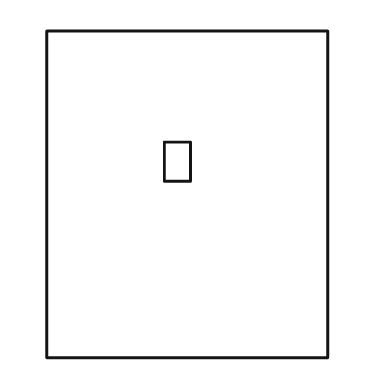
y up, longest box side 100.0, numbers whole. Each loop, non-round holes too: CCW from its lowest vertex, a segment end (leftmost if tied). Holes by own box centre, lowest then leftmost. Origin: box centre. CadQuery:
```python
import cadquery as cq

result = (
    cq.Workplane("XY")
    .moveTo(-43.0, -50.0)
    .lineTo(43.0, -50.0)
    .lineTo(43.0, 50.0)
    .lineTo(-43.0, 50.0)
    .close()
    .moveTo(-7.0, 4.0)
    .lineTo(1.0, 4.0)
    .lineTo(1.0, 16.0)
    .lineTo(-7.0, 16.0)
    .close()
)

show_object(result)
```